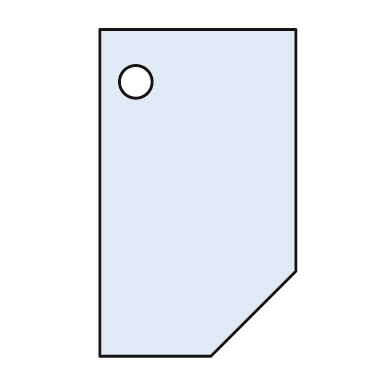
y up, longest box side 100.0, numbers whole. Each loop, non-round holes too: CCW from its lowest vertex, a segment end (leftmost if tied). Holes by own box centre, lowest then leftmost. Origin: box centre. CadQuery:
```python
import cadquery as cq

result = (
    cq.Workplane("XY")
    .moveTo(-30.0, -50.0)
    .lineTo(4.0, -50.0)
    .lineTo(30.0, -24.0)
    .lineTo(30.0, 50.0)
    .lineTo(-30.0, 50.0)
    .close()
    .moveTo(-19.0, 34.0)
    .circle(5.0)
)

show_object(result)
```